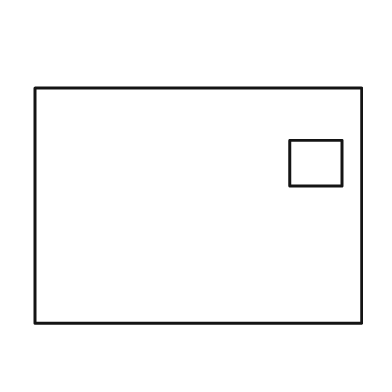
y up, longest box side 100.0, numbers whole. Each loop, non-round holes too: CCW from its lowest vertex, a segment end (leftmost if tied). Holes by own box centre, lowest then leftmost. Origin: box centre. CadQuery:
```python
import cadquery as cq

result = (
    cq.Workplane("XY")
    .moveTo(-50.0, -36.0)
    .lineTo(50.0, -36.0)
    .lineTo(50.0, 36.0)
    .lineTo(-50.0, 36.0)
    .close()
    .moveTo(28.0, 6.0)
    .lineTo(44.0, 6.0)
    .lineTo(44.0, 20.0)
    .lineTo(28.0, 20.0)
    .close()
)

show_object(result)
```